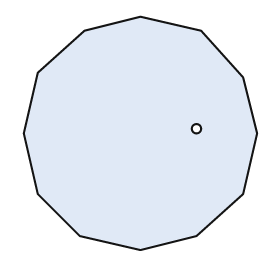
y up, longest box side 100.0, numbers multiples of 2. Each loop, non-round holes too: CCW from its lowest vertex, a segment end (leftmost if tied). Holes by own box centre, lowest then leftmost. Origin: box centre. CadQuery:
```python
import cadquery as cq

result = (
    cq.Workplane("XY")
    .moveTo(0.0, -50.0)
    .lineTo(24.0, -44.0)
    .lineTo(44.0, -26.0)
    .lineTo(50.0, 0.0)
    .lineTo(44.0, 24.0)
    .lineTo(26.0, 44.0)
    .lineTo(0.0, 50.0)
    .lineTo(-24.0, 44.0)
    .lineTo(-44.0, 26.0)
    .lineTo(-50.0, 0.0)
    .lineTo(-44.0, -26.0)
    .lineTo(-26.0, -44.0)
    .close()
    .moveTo(24.0, 2.0)
    .circle(2.0)
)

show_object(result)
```